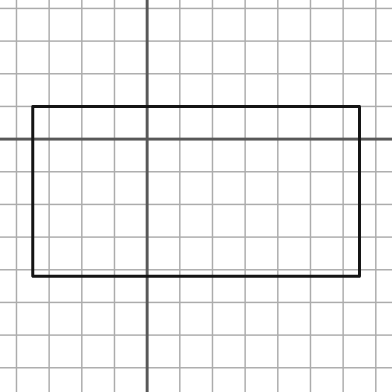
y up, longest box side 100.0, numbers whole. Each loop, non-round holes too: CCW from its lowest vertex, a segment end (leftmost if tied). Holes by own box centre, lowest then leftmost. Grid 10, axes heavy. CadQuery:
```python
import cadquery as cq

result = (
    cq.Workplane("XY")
    .moveTo(-35.0, -42.0)
    .lineTo(65.0, -42.0)
    .lineTo(65.0, 10.0)
    .lineTo(-35.0, 10.0)
    .close()
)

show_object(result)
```